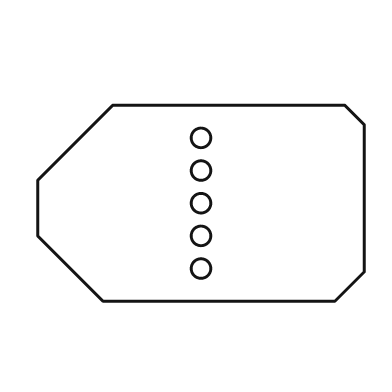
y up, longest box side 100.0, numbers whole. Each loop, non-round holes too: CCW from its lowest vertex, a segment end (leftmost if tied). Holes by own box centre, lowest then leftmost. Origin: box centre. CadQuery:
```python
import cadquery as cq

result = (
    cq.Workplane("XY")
    .moveTo(-30.0, -30.0)
    .lineTo(41.0, -30.0)
    .lineTo(50.0, -21.0)
    .lineTo(50.0, 24.0)
    .lineTo(44.0, 30.0)
    .lineTo(-27.0, 30.0)
    .lineTo(-50.0, 7.0)
    .lineTo(-50.0, -10.0)
    .close()
    .moveTo(0.0, -20.0)
    .circle(3.0)
    .moveTo(0.0, -10.0)
    .circle(3.0)
    .moveTo(0.0, 0.0)
    .circle(3.0)
    .moveTo(0.0, 10.0)
    .circle(3.0)
    .moveTo(0.0, 20.0)
    .circle(3.0)
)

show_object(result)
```